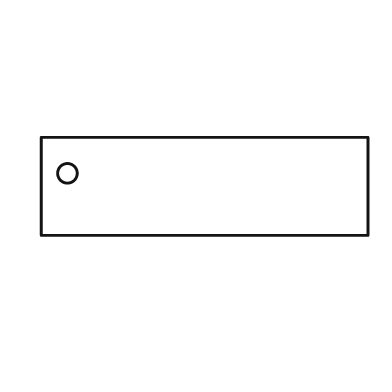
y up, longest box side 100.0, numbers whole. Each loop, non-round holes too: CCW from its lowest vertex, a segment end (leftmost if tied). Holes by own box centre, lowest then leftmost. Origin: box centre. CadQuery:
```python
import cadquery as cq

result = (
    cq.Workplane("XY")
    .moveTo(-50.0, -15.0)
    .lineTo(50.0, -15.0)
    .lineTo(50.0, 15.0)
    .lineTo(-50.0, 15.0)
    .close()
    .moveTo(-42.0, 4.0)
    .circle(3.0)
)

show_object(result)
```